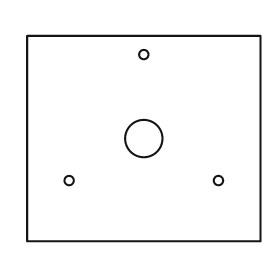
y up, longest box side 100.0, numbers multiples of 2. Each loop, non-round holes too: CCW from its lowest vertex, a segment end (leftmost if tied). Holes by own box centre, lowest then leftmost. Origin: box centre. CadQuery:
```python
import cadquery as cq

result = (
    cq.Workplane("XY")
    .moveTo(-50.0, -44.0)
    .lineTo(50.0, -44.0)
    .lineTo(50.0, 44.0)
    .lineTo(-50.0, 44.0)
    .close()
    .moveTo(-32.0, -18.0)
    .circle(2.0)
    .moveTo(32.0, -18.0)
    .circle(2.0)
    .moveTo(0.0, 0.0)
    .circle(8.0)
    .moveTo(0.0, 36.0)
    .circle(2.0)
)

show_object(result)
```